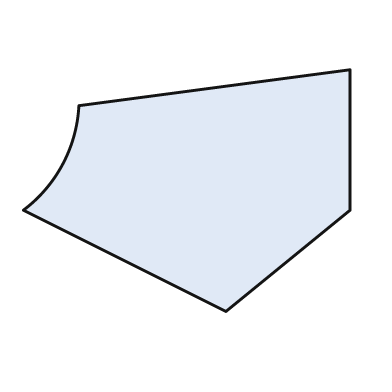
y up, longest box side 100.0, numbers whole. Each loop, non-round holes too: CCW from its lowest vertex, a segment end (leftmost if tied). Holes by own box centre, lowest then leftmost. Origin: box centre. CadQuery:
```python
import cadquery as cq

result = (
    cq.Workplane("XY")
    .moveTo(12.0, -37.0)
    .lineTo(50.0, -6.0)
    .lineTo(50.0, 37.0)
    .lineTo(-33.0, 26.0)
    .threePointArc((-38.0, 8.0), (-50.0, -6.0))
    .close()
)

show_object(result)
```